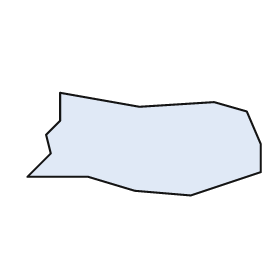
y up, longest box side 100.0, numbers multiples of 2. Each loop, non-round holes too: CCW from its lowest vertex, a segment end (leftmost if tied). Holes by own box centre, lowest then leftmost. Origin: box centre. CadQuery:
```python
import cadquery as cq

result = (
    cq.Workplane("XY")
    .moveTo(20.0, -22.0)
    .lineTo(50.0, -12.0)
    .lineTo(50.0, 0.0)
    .lineTo(44.0, 14.0)
    .lineTo(30.0, 18.0)
    .lineTo(-2.0, 16.0)
    .lineTo(-36.0, 22.0)
    .lineTo(-36.0, 10.0)
    .lineTo(-42.0, 4.0)
    .lineTo(-40.0, -4.0)
    .lineTo(-50.0, -14.0)
    .lineTo(-24.0, -14.0)
    .lineTo(-4.0, -20.0)
    .close()
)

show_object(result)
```